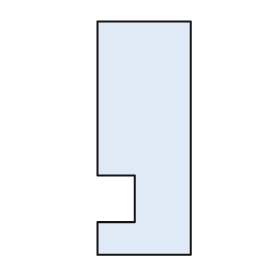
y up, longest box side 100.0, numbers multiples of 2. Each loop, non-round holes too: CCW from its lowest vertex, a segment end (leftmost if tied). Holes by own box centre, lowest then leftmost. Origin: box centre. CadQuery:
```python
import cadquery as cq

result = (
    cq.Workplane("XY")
    .moveTo(-20.0, -50.0)
    .lineTo(20.0, -50.0)
    .lineTo(20.0, 50.0)
    .lineTo(-20.0, 50.0)
    .lineTo(-20.0, -16.0)
    .lineTo(-4.0, -16.0)
    .lineTo(-4.0, -36.0)
    .lineTo(-20.0, -36.0)
    .close()
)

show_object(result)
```